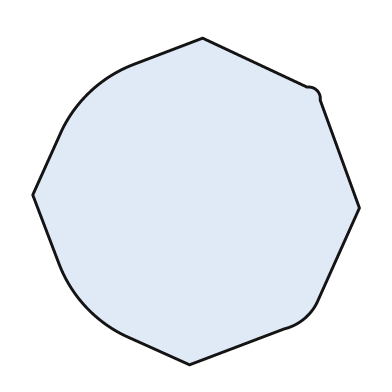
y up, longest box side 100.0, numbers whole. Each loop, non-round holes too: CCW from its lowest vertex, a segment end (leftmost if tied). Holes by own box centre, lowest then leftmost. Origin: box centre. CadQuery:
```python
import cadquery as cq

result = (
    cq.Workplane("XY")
    .moveTo(-2.0, -50.0)
    .lineTo(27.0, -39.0)
    .threePointArc((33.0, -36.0), (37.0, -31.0))
    .lineTo(50.0, -2.0)
    .lineTo(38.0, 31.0)
    .threePointArc((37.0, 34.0), (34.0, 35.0))
    .lineTo(2.0, 50.0)
    .lineTo(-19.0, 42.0)
    .threePointArc((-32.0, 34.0), (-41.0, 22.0))
    .lineTo(-50.0, 2.0)
    .lineTo(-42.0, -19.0)
    .threePointArc((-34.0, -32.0), (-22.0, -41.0))
    .close()
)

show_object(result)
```